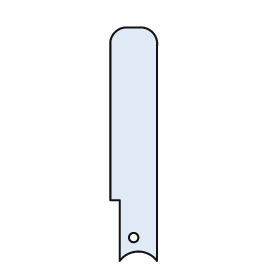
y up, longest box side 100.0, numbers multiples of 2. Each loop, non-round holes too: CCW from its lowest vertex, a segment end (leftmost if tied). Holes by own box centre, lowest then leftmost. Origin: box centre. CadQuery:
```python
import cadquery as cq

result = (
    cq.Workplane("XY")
    .moveTo(-6.0, -50.0)
    .threePointArc((2.0, -46.0), (10.0, -50.0))
    .lineTo(10.0, 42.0)
    .threePointArc((8.0, 48.0), (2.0, 50.0))
    .lineTo(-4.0, 50.0)
    .threePointArc((-8.0, 48.0), (-10.0, 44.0))
    .lineTo(-10.0, -24.0)
    .lineTo(-6.0, -24.0)
    .close()
    .moveTo(0.0, -40.0)
    .circle(2.0)
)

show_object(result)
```